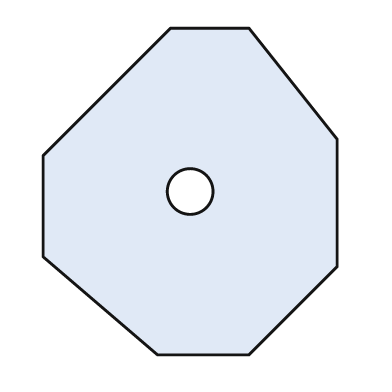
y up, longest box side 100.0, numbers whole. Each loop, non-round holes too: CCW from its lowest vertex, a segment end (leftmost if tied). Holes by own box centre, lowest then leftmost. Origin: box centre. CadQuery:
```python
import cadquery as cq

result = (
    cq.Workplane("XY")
    .moveTo(-10.0, -50.0)
    .lineTo(18.0, -50.0)
    .lineTo(45.0, -23.0)
    .lineTo(45.0, 16.0)
    .lineTo(18.0, 50.0)
    .lineTo(-6.0, 50.0)
    .lineTo(-45.0, 11.0)
    .lineTo(-45.0, -20.0)
    .close()
    .moveTo(0.0, 0.0)
    .circle(7.0)
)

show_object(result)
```